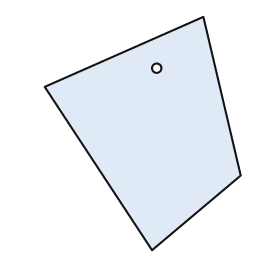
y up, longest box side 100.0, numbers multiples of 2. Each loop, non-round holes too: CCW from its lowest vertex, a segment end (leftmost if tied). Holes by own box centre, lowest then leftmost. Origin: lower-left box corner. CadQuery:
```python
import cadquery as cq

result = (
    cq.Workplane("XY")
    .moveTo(46.0, 0.0)
    .lineTo(84.0, 32.0)
    .lineTo(68.0, 100.0)
    .lineTo(0.0, 70.0)
    .close()
    .moveTo(48.0, 78.0)
    .circle(2.0)
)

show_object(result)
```